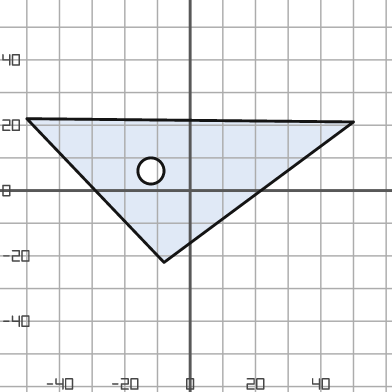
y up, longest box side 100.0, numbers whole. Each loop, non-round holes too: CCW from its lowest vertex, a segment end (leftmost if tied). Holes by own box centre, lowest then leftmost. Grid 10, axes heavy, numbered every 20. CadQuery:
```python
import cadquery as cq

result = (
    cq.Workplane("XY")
    .moveTo(-8.0, -22.0)
    .lineTo(50.0, 21.0)
    .lineTo(-50.0, 22.0)
    .close()
    .moveTo(-12.0, 6.0)
    .circle(4.0)
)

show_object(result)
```